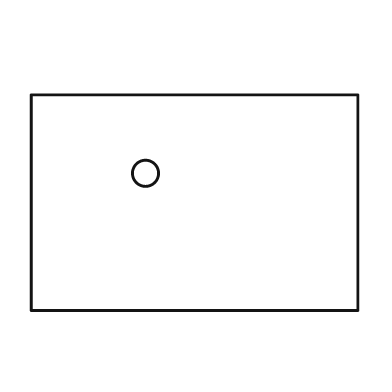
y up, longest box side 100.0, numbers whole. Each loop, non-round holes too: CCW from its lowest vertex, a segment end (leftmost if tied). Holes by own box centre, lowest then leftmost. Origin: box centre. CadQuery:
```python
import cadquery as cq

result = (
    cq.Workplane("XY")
    .moveTo(-50.0, -33.0)
    .lineTo(50.0, -33.0)
    .lineTo(50.0, 33.0)
    .lineTo(-50.0, 33.0)
    .close()
    .moveTo(-15.0, 9.0)
    .circle(4.0)
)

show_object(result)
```